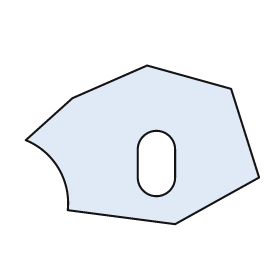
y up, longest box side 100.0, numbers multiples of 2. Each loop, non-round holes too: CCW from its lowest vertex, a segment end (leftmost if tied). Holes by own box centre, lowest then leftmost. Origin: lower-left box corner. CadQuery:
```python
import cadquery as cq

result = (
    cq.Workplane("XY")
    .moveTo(64.0, 0.0)
    .lineTo(100.0, 20.0)
    .lineTo(88.0, 58.0)
    .lineTo(52.0, 68.0)
    .lineTo(20.0, 54.0)
    .lineTo(0.0, 36.0)
    .threePointArc((14.0, 24.0), (18.0, 6.0))
    .close()
    .moveTo(48.0, 20.0)
    .threePointArc((56.0, 12.0), (64.0, 20.0))
    .lineTo(64.0, 32.0)
    .threePointArc((56.0, 40.0), (48.0, 32.0))
    .close()
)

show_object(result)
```